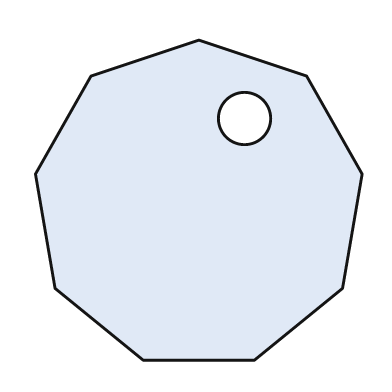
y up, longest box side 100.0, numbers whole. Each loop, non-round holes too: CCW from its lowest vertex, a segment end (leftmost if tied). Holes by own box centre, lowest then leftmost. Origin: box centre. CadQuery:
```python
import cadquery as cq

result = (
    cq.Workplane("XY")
    .moveTo(-17.0, -49.0)
    .lineTo(17.0, -49.0)
    .lineTo(44.0, -27.0)
    .lineTo(50.0, 8.0)
    .lineTo(33.0, 38.0)
    .lineTo(0.0, 49.0)
    .lineTo(-33.0, 38.0)
    .lineTo(-50.0, 8.0)
    .lineTo(-44.0, -27.0)
    .close()
    .moveTo(14.0, 25.0)
    .circle(8.0)
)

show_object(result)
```